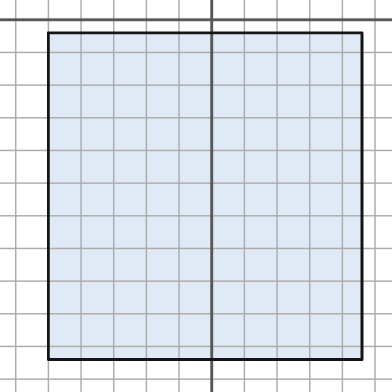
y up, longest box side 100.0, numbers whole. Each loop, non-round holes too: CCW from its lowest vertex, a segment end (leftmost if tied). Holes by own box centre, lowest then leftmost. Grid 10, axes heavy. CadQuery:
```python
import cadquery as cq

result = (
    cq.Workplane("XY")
    .moveTo(-50.0, -104.0)
    .lineTo(46.0, -104.0)
    .lineTo(46.0, -4.0)
    .lineTo(-50.0, -4.0)
    .close()
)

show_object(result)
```